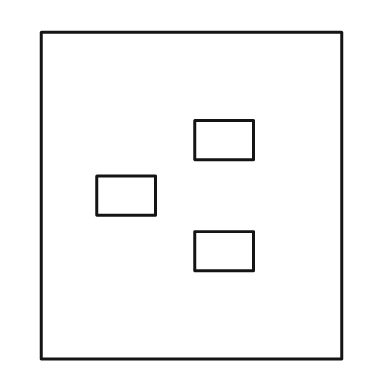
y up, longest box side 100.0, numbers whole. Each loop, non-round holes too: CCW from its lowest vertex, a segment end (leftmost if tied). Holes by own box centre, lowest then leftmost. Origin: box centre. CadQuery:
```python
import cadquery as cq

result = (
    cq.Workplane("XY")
    .moveTo(-46.0, -50.0)
    .lineTo(46.0, -50.0)
    .lineTo(46.0, 50.0)
    .lineTo(-46.0, 50.0)
    .close()
    .moveTo(1.0, -23.0)
    .lineTo(19.0, -23.0)
    .lineTo(19.0, -11.0)
    .lineTo(1.0, -11.0)
    .close()
    .moveTo(-29.0, -6.0)
    .lineTo(-11.0, -6.0)
    .lineTo(-11.0, 6.0)
    .lineTo(-29.0, 6.0)
    .close()
    .moveTo(1.0, 11.0)
    .lineTo(19.0, 11.0)
    .lineTo(19.0, 23.0)
    .lineTo(1.0, 23.0)
    .close()
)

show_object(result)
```